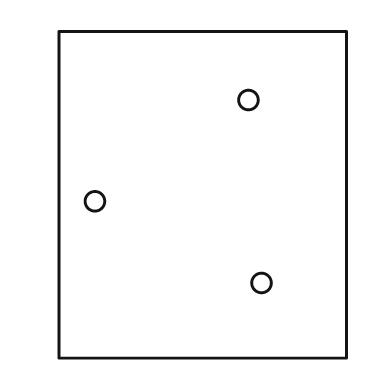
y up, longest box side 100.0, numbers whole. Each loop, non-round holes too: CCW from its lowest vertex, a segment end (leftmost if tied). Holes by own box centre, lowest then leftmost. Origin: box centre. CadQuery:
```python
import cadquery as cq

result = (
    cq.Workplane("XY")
    .moveTo(-44.0, -50.0)
    .lineTo(44.0, -50.0)
    .lineTo(44.0, 50.0)
    .lineTo(-44.0, 50.0)
    .close()
    .moveTo(18.0, -27.0)
    .circle(3.0)
    .moveTo(-33.0, -2.0)
    .circle(3.0)
    .moveTo(14.0, 29.0)
    .circle(3.0)
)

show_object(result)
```